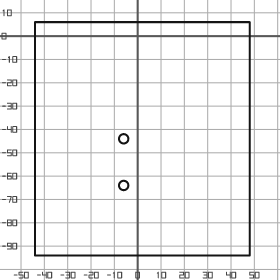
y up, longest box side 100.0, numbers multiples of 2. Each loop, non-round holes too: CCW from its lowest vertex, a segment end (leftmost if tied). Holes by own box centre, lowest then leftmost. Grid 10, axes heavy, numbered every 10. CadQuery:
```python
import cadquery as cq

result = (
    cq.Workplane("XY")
    .moveTo(-44.0, -94.0)
    .lineTo(48.0, -94.0)
    .lineTo(48.0, 6.0)
    .lineTo(-44.0, 6.0)
    .close()
    .moveTo(-6.0, -64.0)
    .circle(2.0)
    .moveTo(-6.0, -44.0)
    .circle(2.0)
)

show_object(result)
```